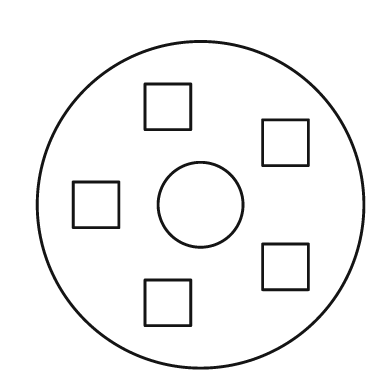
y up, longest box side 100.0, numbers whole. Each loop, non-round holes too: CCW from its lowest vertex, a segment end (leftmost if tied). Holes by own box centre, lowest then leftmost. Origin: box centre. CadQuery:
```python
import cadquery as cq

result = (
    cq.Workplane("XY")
    .moveTo(0.0, 0.0)
    .circle(50.0)
    .moveTo(-17.0, -37.0)
    .lineTo(-3.0, -37.0)
    .lineTo(-3.0, -23.0)
    .lineTo(-17.0, -23.0)
    .close()
    .moveTo(19.0, -26.0)
    .lineTo(33.0, -26.0)
    .lineTo(33.0, -12.0)
    .lineTo(19.0, -12.0)
    .close()
    .moveTo(-39.0, -7.0)
    .lineTo(-25.0, -7.0)
    .lineTo(-25.0, 7.0)
    .lineTo(-39.0, 7.0)
    .close()
    .moveTo(0.0, 0.0)
    .circle(13.0)
    .moveTo(19.0, 12.0)
    .lineTo(33.0, 12.0)
    .lineTo(33.0, 26.0)
    .lineTo(19.0, 26.0)
    .close()
    .moveTo(-17.0, 23.0)
    .lineTo(-3.0, 23.0)
    .lineTo(-3.0, 37.0)
    .lineTo(-17.0, 37.0)
    .close()
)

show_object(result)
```